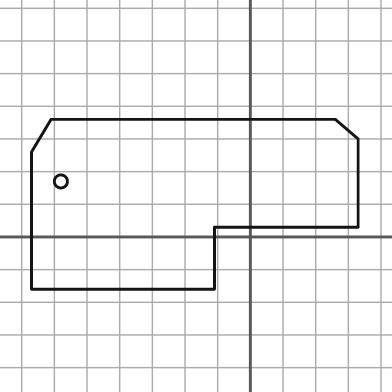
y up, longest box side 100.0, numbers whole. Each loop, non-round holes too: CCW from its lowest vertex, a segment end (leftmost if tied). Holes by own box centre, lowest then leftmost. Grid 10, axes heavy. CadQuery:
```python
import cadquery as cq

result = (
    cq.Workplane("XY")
    .moveTo(-67.0, -16.0)
    .lineTo(-11.0, -16.0)
    .lineTo(-11.0, 3.0)
    .lineTo(33.0, 3.0)
    .lineTo(33.0, 30.0)
    .lineTo(26.0, 36.0)
    .lineTo(-61.0, 36.0)
    .lineTo(-67.0, 26.0)
    .close()
    .moveTo(-58.0, 17.0)
    .circle(2.0)
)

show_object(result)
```